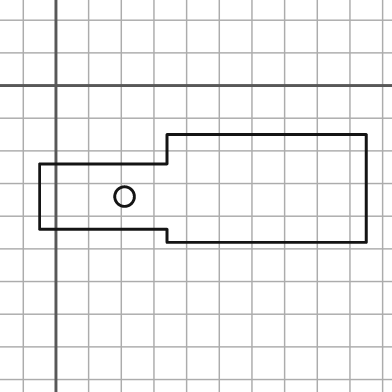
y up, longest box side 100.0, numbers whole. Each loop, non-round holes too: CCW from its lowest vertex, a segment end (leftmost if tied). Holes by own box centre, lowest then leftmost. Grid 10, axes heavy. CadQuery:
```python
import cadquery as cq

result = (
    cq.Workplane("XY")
    .moveTo(34.0, -48.0)
    .lineTo(95.0, -48.0)
    .lineTo(95.0, -15.0)
    .lineTo(34.0, -15.0)
    .lineTo(34.0, -24.0)
    .lineTo(-5.0, -24.0)
    .lineTo(-5.0, -44.0)
    .lineTo(34.0, -44.0)
    .close()
    .moveTo(21.0, -34.0)
    .circle(3.0)
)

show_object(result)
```